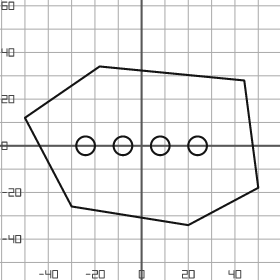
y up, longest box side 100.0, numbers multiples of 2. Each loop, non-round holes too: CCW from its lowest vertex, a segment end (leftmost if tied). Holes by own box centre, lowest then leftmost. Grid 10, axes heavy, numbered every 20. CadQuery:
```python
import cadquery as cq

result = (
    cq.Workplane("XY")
    .moveTo(20.0, -34.0)
    .lineTo(50.0, -18.0)
    .lineTo(44.0, 28.0)
    .lineTo(-18.0, 34.0)
    .lineTo(-50.0, 12.0)
    .lineTo(-30.0, -26.0)
    .close()
    .moveTo(-24.0, 0.0)
    .circle(4.0)
    .moveTo(-8.0, 0.0)
    .circle(4.0)
    .moveTo(8.0, 0.0)
    .circle(4.0)
    .moveTo(24.0, 0.0)
    .circle(4.0)
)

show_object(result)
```